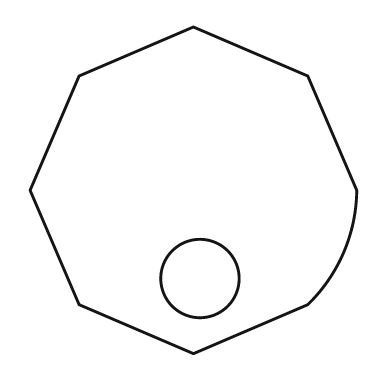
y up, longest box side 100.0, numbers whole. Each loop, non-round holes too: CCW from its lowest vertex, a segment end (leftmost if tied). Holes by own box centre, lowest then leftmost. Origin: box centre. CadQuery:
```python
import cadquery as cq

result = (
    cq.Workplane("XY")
    .moveTo(0.0, -50.0)
    .lineTo(35.0, -35.0)
    .threePointArc((46.0, -19.0), (50.0, 0.0))
    .lineTo(35.0, 35.0)
    .lineTo(0.0, 50.0)
    .lineTo(-35.0, 35.0)
    .lineTo(-50.0, 0.0)
    .lineTo(-35.0, -35.0)
    .close()
    .moveTo(2.0, -27.0)
    .circle(12.0)
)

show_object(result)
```